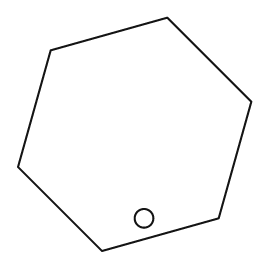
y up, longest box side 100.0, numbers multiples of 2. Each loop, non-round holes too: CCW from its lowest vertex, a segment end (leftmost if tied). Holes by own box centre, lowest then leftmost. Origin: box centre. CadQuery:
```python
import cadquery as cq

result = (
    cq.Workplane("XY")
    .moveTo(-14.0, -50.0)
    .lineTo(36.0, -36.0)
    .lineTo(50.0, 14.0)
    .lineTo(14.0, 50.0)
    .lineTo(-36.0, 36.0)
    .lineTo(-50.0, -14.0)
    .close()
    .moveTo(4.0, -36.0)
    .circle(4.0)
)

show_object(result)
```